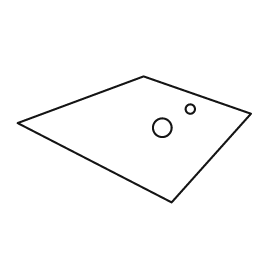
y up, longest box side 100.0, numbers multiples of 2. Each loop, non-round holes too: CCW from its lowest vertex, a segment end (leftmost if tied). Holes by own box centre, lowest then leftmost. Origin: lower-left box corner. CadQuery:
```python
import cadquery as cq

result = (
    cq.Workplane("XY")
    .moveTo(66.0, 0.0)
    .lineTo(100.0, 38.0)
    .lineTo(54.0, 54.0)
    .lineTo(0.0, 34.0)
    .close()
    .moveTo(62.0, 32.0)
    .circle(4.0)
    .moveTo(74.0, 40.0)
    .circle(2.0)
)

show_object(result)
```